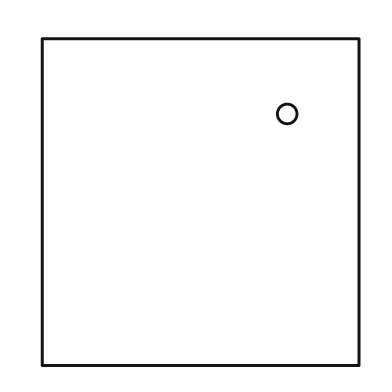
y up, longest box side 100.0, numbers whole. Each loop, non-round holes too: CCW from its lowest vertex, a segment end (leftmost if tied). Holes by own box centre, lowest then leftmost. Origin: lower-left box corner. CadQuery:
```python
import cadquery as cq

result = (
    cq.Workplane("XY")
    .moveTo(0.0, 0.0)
    .lineTo(97.0, 0.0)
    .lineTo(97.0, 100.0)
    .lineTo(0.0, 100.0)
    .close()
    .moveTo(75.0, 77.0)
    .circle(3.0)
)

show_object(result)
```